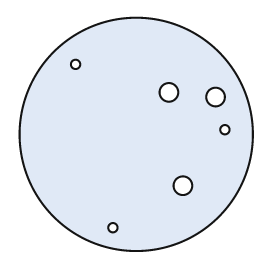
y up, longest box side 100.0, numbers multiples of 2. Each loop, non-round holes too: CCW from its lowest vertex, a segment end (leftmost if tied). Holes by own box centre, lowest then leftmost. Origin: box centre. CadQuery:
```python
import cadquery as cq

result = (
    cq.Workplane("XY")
    .moveTo(0.0, 0.0)
    .circle(50.0)
    .moveTo(-10.0, -40.0)
    .circle(2.0)
    .moveTo(20.0, -22.0)
    .circle(4.0)
    .moveTo(38.0, 2.0)
    .circle(2.0)
    .moveTo(34.0, 16.0)
    .circle(4.0)
    .moveTo(14.0, 18.0)
    .circle(4.0)
    .moveTo(-26.0, 30.0)
    .circle(2.0)
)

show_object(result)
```